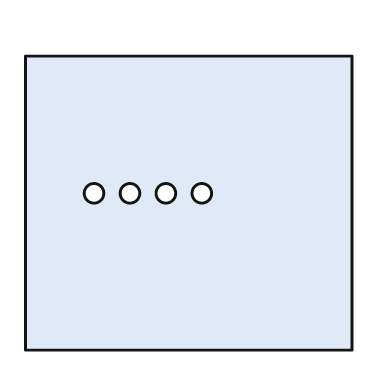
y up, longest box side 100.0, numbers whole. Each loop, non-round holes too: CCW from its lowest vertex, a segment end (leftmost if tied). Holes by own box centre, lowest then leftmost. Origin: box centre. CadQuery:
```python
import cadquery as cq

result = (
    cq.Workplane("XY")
    .moveTo(-50.0, -45.0)
    .lineTo(50.0, -45.0)
    .lineTo(50.0, 45.0)
    .lineTo(-50.0, 45.0)
    .close()
    .moveTo(-29.0, 3.0)
    .circle(3.0)
    .moveTo(-18.0, 3.0)
    .circle(3.0)
    .moveTo(-7.0, 3.0)
    .circle(3.0)
    .moveTo(4.0, 3.0)
    .circle(3.0)
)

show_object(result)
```